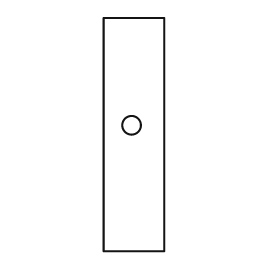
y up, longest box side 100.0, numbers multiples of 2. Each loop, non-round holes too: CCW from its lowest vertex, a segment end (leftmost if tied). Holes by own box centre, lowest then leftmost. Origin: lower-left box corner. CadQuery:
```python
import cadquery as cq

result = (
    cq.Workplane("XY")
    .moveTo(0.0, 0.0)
    .lineTo(26.0, 0.0)
    .lineTo(26.0, 100.0)
    .lineTo(0.0, 100.0)
    .close()
    .moveTo(12.0, 54.0)
    .circle(4.0)
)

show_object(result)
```